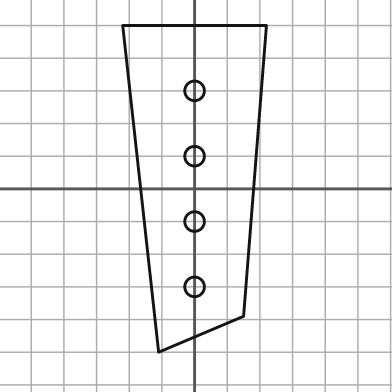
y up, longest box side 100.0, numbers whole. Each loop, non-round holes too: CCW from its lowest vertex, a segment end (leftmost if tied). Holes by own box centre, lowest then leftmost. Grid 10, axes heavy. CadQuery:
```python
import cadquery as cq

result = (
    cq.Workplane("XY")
    .moveTo(-11.0, -50.0)
    .lineTo(15.0, -39.0)
    .lineTo(22.0, 50.0)
    .lineTo(-22.0, 50.0)
    .close()
    .moveTo(0.0, -30.0)
    .circle(3.0)
    .moveTo(0.0, -10.0)
    .circle(3.0)
    .moveTo(0.0, 10.0)
    .circle(3.0)
    .moveTo(0.0, 30.0)
    .circle(3.0)
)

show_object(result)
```